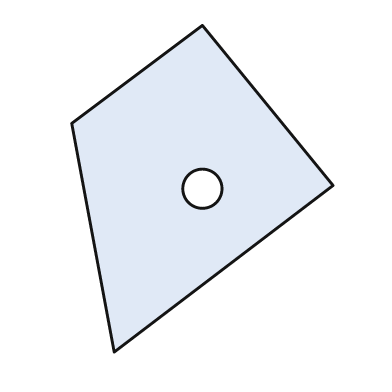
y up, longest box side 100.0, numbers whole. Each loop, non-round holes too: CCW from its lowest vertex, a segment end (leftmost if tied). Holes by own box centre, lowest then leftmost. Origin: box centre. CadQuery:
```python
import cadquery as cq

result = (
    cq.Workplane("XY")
    .moveTo(-27.0, -50.0)
    .lineTo(40.0, 1.0)
    .lineTo(0.0, 50.0)
    .lineTo(-40.0, 20.0)
    .close()
    .moveTo(0.0, 0.0)
    .circle(6.0)
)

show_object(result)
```